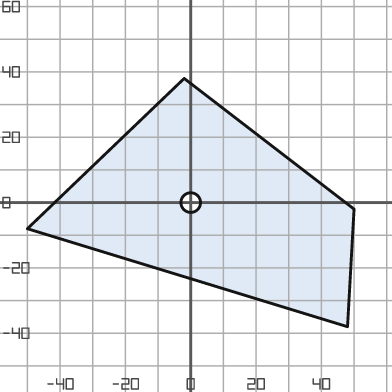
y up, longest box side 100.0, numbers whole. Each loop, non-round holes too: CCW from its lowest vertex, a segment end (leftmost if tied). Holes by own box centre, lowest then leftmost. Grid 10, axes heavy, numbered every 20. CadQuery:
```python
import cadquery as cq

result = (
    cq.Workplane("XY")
    .moveTo(48.0, -38.0)
    .lineTo(50.0, -2.0)
    .lineTo(-2.0, 38.0)
    .lineTo(-50.0, -8.0)
    .close()
    .moveTo(0.0, 0.0)
    .circle(3.0)
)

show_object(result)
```